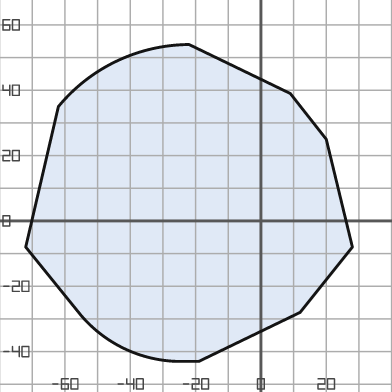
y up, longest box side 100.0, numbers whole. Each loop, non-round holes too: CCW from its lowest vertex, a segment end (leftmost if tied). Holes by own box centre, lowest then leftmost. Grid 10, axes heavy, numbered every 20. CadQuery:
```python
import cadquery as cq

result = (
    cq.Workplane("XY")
    .moveTo(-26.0, -43.0)
    .lineTo(-19.0, -43.0)
    .lineTo(12.0, -28.0)
    .lineTo(28.0, -8.0)
    .lineTo(20.0, 25.0)
    .lineTo(9.0, 39.0)
    .lineTo(-22.0, 54.0)
    .threePointArc((-44.0, 49.0), (-62.0, 35.0))
    .lineTo(-72.0, -8.0)
    .lineTo(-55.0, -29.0)
    .threePointArc((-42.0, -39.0), (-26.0, -43.0))
    .close()
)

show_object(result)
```